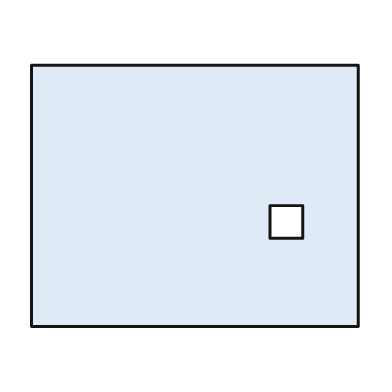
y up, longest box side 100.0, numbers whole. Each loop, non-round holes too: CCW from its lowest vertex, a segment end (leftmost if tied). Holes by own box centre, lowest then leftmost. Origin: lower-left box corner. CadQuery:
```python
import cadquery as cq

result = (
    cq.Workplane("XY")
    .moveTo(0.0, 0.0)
    .lineTo(100.0, 0.0)
    .lineTo(100.0, 80.0)
    .lineTo(0.0, 80.0)
    .close()
    .moveTo(73.0, 27.0)
    .lineTo(83.0, 27.0)
    .lineTo(83.0, 37.0)
    .lineTo(73.0, 37.0)
    .close()
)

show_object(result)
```